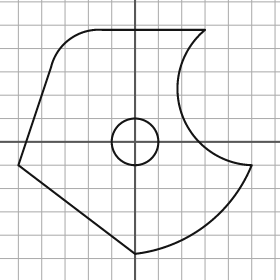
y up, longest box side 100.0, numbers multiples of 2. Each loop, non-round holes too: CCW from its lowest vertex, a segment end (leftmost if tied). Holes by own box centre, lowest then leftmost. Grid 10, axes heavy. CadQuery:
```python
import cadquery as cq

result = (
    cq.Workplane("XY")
    .moveTo(0.0, -48.0)
    .threePointArc((30.0, -36.0), (50.0, -10.0))
    .threePointArc((20.0, 12.0), (30.0, 48.0))
    .lineTo(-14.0, 48.0)
    .threePointArc((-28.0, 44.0), (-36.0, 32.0))
    .lineTo(-50.0, -10.0)
    .close()
    .moveTo(0.0, 0.0)
    .circle(10.0)
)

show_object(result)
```